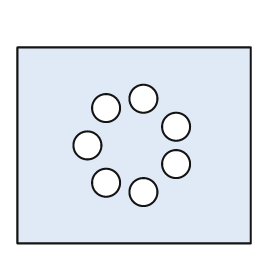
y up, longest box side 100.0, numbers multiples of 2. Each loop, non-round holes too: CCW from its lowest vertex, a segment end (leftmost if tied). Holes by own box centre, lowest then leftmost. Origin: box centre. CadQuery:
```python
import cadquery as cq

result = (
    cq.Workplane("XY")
    .moveTo(-50.0, -42.0)
    .lineTo(50.0, -42.0)
    .lineTo(50.0, 42.0)
    .lineTo(-50.0, 42.0)
    .close()
    .moveTo(4.0, -20.0)
    .circle(6.0)
    .moveTo(-12.0, -16.0)
    .circle(6.0)
    .moveTo(18.0, -8.0)
    .circle(6.0)
    .moveTo(-20.0, 0.0)
    .circle(6.0)
    .moveTo(18.0, 8.0)
    .circle(6.0)
    .moveTo(-12.0, 16.0)
    .circle(6.0)
    .moveTo(4.0, 20.0)
    .circle(6.0)
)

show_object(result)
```